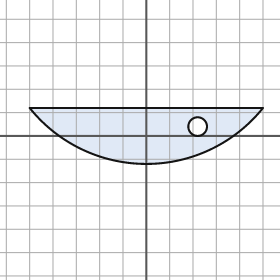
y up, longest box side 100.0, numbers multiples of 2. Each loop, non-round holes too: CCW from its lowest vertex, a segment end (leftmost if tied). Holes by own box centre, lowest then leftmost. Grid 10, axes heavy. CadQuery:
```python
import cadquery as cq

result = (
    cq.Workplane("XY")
    .moveTo(-50.0, 12.0)
    .threePointArc((0.0, -12.0), (50.0, 12.0))
    .close()
    .moveTo(22.0, 4.0)
    .circle(4.0)
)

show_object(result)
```